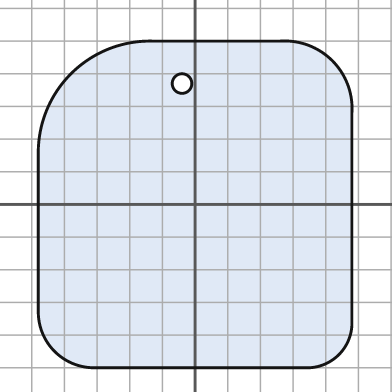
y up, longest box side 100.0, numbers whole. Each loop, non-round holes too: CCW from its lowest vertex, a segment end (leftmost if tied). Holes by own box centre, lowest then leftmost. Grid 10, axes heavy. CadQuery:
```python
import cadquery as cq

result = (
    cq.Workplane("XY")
    .moveTo(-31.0, -50.0)
    .lineTo(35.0, -50.0)
    .threePointArc((44.0, -46.0), (48.0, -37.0))
    .lineTo(48.0, 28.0)
    .threePointArc((42.0, 44.0), (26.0, 50.0))
    .lineTo(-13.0, 50.0)
    .threePointArc((-38.0, 40.0), (-48.0, 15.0))
    .lineTo(-48.0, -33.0)
    .threePointArc((-43.0, -45.0), (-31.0, -50.0))
    .close()
    .moveTo(-4.0, 37.0)
    .circle(3.0)
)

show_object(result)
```